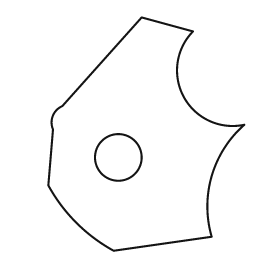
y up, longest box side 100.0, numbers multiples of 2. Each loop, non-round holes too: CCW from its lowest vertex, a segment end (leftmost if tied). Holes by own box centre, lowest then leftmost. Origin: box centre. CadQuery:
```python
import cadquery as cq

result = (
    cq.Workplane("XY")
    .moveTo(-14.0, -50.0)
    .lineTo(28.0, -44.0)
    .threePointArc((28.0, -18.0), (42.0, 4.0))
    .threePointArc((16.0, 16.0), (20.0, 44.0))
    .lineTo(-2.0, 50.0)
    .lineTo(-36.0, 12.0)
    .threePointArc((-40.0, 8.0), (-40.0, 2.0))
    .lineTo(-42.0, -22.0)
    .threePointArc((-30.0, -38.0), (-14.0, -50.0))
    .close()
    .moveTo(-12.0, -10.0)
    .circle(10.0)
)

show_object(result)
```